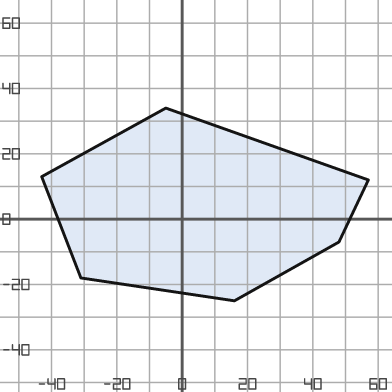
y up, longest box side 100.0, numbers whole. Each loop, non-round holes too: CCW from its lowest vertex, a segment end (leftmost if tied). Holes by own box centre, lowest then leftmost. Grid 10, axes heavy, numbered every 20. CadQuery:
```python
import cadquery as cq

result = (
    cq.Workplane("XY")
    .moveTo(16.0, -25.0)
    .lineTo(48.0, -7.0)
    .lineTo(57.0, 12.0)
    .lineTo(-5.0, 34.0)
    .lineTo(-43.0, 13.0)
    .lineTo(-31.0, -18.0)
    .close()
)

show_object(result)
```